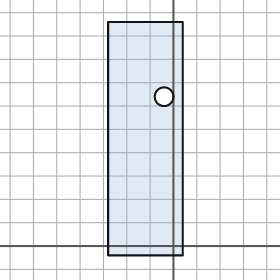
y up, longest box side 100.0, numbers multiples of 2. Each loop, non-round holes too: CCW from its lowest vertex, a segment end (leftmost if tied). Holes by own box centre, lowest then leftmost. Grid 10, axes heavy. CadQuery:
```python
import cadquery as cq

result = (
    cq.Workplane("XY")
    .moveTo(-28.0, -4.0)
    .lineTo(4.0, -4.0)
    .lineTo(4.0, 96.0)
    .lineTo(-28.0, 96.0)
    .close()
    .moveTo(-4.0, 64.0)
    .circle(4.0)
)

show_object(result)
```